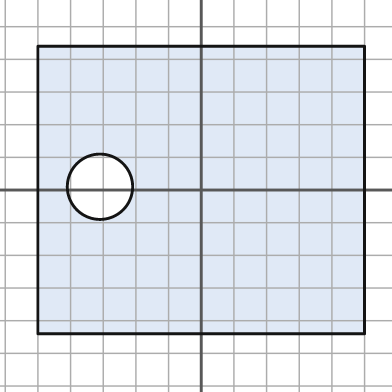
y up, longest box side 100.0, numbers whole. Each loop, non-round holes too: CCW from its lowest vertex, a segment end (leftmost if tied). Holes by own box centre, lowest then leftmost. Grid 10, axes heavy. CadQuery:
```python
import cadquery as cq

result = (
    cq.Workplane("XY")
    .moveTo(-50.0, -44.0)
    .lineTo(50.0, -44.0)
    .lineTo(50.0, 44.0)
    .lineTo(-50.0, 44.0)
    .close()
    .moveTo(-31.0, 1.0)
    .circle(10.0)
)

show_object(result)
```